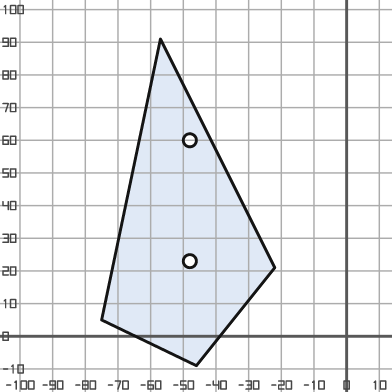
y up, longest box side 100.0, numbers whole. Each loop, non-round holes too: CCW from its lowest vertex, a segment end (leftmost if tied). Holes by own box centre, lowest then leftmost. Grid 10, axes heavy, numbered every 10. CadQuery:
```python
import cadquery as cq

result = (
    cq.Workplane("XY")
    .moveTo(-46.0, -9.0)
    .lineTo(-22.0, 21.0)
    .lineTo(-57.0, 91.0)
    .lineTo(-75.0, 5.0)
    .close()
    .moveTo(-48.0, 23.0)
    .circle(2.0)
    .moveTo(-48.0, 60.0)
    .circle(2.0)
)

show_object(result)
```